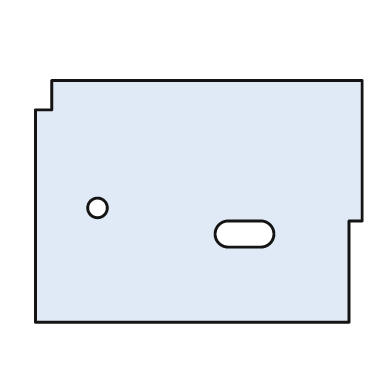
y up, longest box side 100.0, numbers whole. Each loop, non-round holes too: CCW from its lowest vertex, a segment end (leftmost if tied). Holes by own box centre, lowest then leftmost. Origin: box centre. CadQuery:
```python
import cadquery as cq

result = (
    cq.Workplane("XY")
    .moveTo(-50.0, -37.0)
    .lineTo(46.0, -37.0)
    .lineTo(46.0, -6.0)
    .lineTo(50.0, -6.0)
    .lineTo(50.0, 37.0)
    .lineTo(-45.0, 37.0)
    .lineTo(-45.0, 28.0)
    .lineTo(-50.0, 28.0)
    .close()
    .moveTo(9.0, -14.0)
    .lineTo(19.0, -14.0)
    .threePointArc((23.0, -10.0), (19.0, -6.0))
    .lineTo(9.0, -6.0)
    .threePointArc((5.0, -10.0), (9.0, -14.0))
    .close()
    .moveTo(-31.0, -2.0)
    .circle(3.0)
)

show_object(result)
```